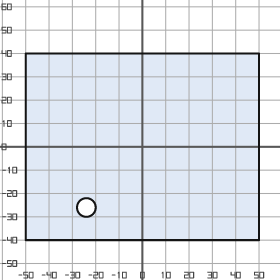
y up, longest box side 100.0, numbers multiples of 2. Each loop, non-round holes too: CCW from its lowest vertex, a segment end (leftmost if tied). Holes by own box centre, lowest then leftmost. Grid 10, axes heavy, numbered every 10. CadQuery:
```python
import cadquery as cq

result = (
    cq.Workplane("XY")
    .moveTo(-50.0, -40.0)
    .lineTo(50.0, -40.0)
    .lineTo(50.0, 40.0)
    .lineTo(-50.0, 40.0)
    .close()
    .moveTo(-24.0, -26.0)
    .circle(4.0)
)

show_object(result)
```